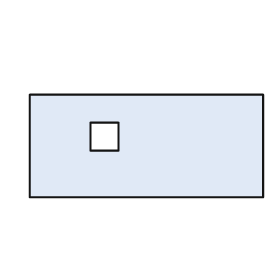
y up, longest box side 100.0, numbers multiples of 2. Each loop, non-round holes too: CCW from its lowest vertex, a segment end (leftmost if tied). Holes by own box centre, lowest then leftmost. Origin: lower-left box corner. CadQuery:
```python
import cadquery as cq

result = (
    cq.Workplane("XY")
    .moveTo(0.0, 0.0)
    .lineTo(100.0, 0.0)
    .lineTo(100.0, 44.0)
    .lineTo(0.0, 44.0)
    .close()
    .moveTo(26.0, 20.0)
    .lineTo(38.0, 20.0)
    .lineTo(38.0, 32.0)
    .lineTo(26.0, 32.0)
    .close()
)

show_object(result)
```